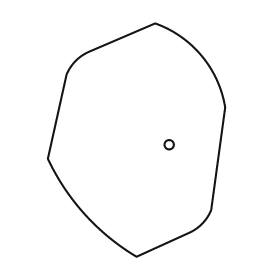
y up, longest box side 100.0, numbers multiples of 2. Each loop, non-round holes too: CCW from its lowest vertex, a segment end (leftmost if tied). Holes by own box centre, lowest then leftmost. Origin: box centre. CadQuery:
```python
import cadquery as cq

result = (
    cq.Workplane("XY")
    .moveTo(0.0, -50.0)
    .lineTo(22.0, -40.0)
    .threePointArc((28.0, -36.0), (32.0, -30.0))
    .lineTo(38.0, 14.0)
    .threePointArc((28.0, 36.0), (8.0, 50.0))
    .lineTo(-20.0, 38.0)
    .threePointArc((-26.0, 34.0), (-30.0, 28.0))
    .lineTo(-38.0, -8.0)
    .threePointArc((-22.0, -32.0), (0.0, -50.0))
    .close()
    .moveTo(14.0, -2.0)
    .circle(2.0)
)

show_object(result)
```